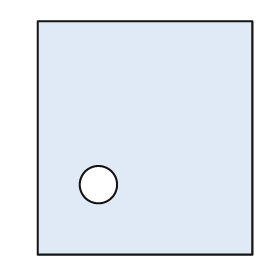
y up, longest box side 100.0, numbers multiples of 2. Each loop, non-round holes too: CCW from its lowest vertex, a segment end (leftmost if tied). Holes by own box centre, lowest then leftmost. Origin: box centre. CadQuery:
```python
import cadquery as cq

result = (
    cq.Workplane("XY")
    .moveTo(-46.0, -50.0)
    .lineTo(46.0, -50.0)
    .lineTo(46.0, 50.0)
    .lineTo(-46.0, 50.0)
    .close()
    .moveTo(-20.0, -20.0)
    .circle(8.0)
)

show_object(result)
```